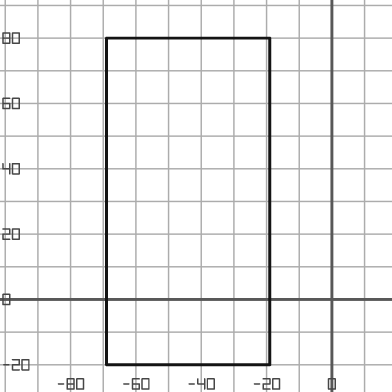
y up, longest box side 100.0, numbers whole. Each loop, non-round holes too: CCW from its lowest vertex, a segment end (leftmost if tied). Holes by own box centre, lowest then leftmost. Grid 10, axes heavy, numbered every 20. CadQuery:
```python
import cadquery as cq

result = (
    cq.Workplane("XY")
    .moveTo(-69.0, -20.0)
    .lineTo(-19.0, -20.0)
    .lineTo(-19.0, 80.0)
    .lineTo(-69.0, 80.0)
    .close()
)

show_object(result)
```